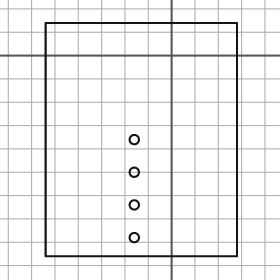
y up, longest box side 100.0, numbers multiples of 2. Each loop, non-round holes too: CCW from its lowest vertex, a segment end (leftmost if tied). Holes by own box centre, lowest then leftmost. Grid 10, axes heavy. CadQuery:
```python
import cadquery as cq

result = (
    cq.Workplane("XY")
    .moveTo(-54.0, -86.0)
    .lineTo(28.0, -86.0)
    .lineTo(28.0, 14.0)
    .lineTo(-54.0, 14.0)
    .close()
    .moveTo(-16.0, -78.0)
    .circle(2.0)
    .moveTo(-16.0, -64.0)
    .circle(2.0)
    .moveTo(-16.0, -50.0)
    .circle(2.0)
    .moveTo(-16.0, -36.0)
    .circle(2.0)
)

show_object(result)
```